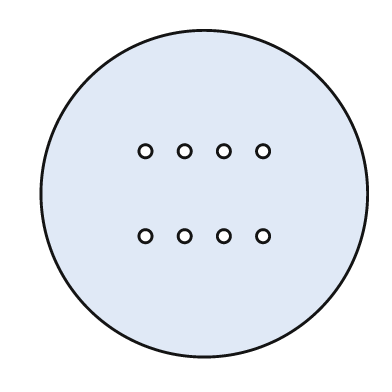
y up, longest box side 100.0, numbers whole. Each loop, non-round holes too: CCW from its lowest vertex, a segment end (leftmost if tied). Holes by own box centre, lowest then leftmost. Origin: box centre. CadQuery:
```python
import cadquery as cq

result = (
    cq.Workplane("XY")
    .moveTo(0.0, 0.0)
    .circle(50.0)
    .moveTo(-18.0, -13.0)
    .circle(2.0)
    .moveTo(-6.0, -13.0)
    .circle(2.0)
    .moveTo(6.0, -13.0)
    .circle(2.0)
    .moveTo(18.0, -13.0)
    .circle(2.0)
    .moveTo(-18.0, 13.0)
    .circle(2.0)
    .moveTo(-6.0, 13.0)
    .circle(2.0)
    .moveTo(6.0, 13.0)
    .circle(2.0)
    .moveTo(18.0, 13.0)
    .circle(2.0)
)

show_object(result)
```